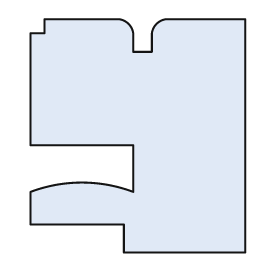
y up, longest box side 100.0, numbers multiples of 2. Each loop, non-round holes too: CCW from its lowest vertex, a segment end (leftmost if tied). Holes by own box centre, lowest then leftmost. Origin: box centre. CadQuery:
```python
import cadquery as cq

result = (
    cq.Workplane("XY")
    .moveTo(-6.0, -50.0)
    .lineTo(46.0, -50.0)
    .lineTo(46.0, 50.0)
    .lineTo(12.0, 50.0)
    .threePointArc((8.0, 48.0), (6.0, 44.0))
    .lineTo(6.0, 36.0)
    .lineTo(-2.0, 36.0)
    .lineTo(-2.0, 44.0)
    .threePointArc((-4.0, 48.0), (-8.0, 50.0))
    .lineTo(-40.0, 50.0)
    .lineTo(-40.0, 44.0)
    .lineTo(-46.0, 44.0)
    .lineTo(-46.0, -4.0)
    .lineTo(-2.0, -4.0)
    .lineTo(-2.0, -24.0)
    .threePointArc((-24.0, -20.0), (-46.0, -24.0))
    .lineTo(-46.0, -38.0)
    .lineTo(-6.0, -38.0)
    .close()
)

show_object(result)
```